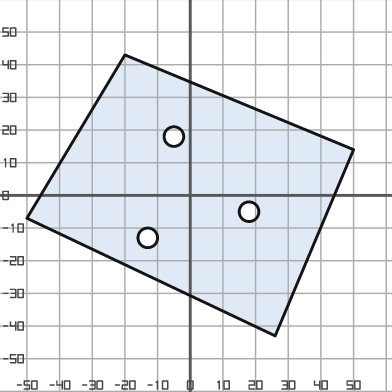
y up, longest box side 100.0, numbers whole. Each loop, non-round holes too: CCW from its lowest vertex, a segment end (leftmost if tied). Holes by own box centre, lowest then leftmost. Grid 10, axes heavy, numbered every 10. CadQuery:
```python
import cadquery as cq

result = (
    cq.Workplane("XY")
    .moveTo(26.0, -43.0)
    .lineTo(50.0, 14.0)
    .lineTo(-20.0, 43.0)
    .lineTo(-50.0, -7.0)
    .close()
    .moveTo(-13.0, -13.0)
    .circle(3.0)
    .moveTo(18.0, -5.0)
    .circle(3.0)
    .moveTo(-5.0, 18.0)
    .circle(3.0)
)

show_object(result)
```